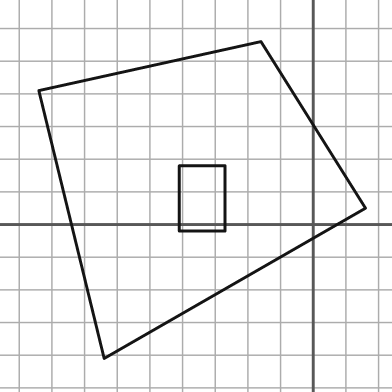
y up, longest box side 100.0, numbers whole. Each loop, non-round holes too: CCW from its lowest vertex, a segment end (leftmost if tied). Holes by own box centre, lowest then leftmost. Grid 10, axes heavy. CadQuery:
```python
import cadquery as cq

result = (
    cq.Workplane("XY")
    .moveTo(-64.0, -41.0)
    .lineTo(16.0, 5.0)
    .lineTo(-16.0, 56.0)
    .lineTo(-84.0, 41.0)
    .close()
    .moveTo(-41.0, -2.0)
    .lineTo(-27.0, -2.0)
    .lineTo(-27.0, 18.0)
    .lineTo(-41.0, 18.0)
    .close()
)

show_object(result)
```